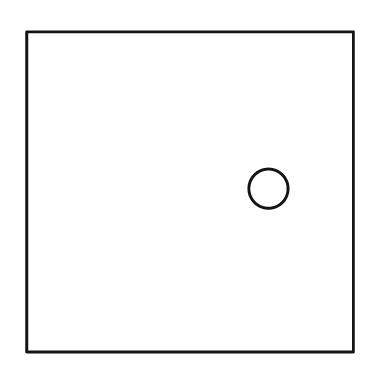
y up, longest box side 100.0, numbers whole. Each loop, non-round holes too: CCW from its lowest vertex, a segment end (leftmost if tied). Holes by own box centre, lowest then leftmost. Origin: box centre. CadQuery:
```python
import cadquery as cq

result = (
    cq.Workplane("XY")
    .moveTo(-50.0, -49.0)
    .lineTo(50.0, -49.0)
    .lineTo(50.0, 49.0)
    .lineTo(-50.0, 49.0)
    .close()
    .moveTo(24.0, 1.0)
    .circle(6.0)
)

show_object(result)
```